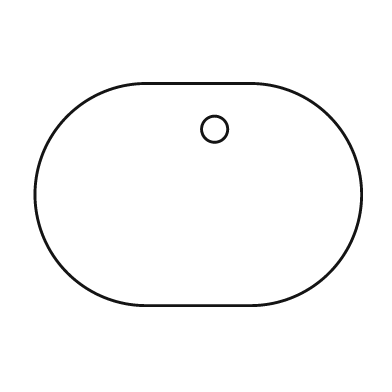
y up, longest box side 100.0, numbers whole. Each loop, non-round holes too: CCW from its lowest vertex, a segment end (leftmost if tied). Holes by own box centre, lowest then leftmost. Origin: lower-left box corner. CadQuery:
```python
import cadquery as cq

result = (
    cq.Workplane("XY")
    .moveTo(34.0, 0.0)
    .lineTo(66.0, 0.0)
    .threePointArc((100.0, 34.0), (66.0, 68.0))
    .lineTo(34.0, 68.0)
    .threePointArc((0.0, 34.0), (34.0, 0.0))
    .close()
    .moveTo(55.0, 54.0)
    .circle(4.0)
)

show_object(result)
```